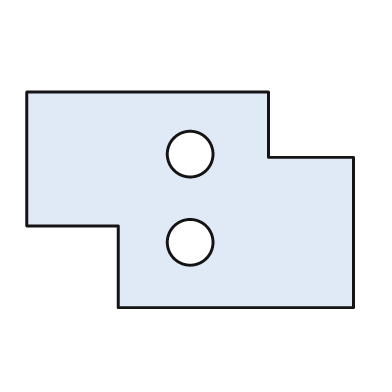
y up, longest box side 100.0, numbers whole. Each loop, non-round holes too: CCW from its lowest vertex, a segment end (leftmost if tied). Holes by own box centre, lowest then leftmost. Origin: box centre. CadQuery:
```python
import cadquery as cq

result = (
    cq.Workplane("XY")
    .moveTo(-22.0, -33.0)
    .lineTo(50.0, -33.0)
    .lineTo(50.0, 13.0)
    .lineTo(24.0, 13.0)
    .lineTo(24.0, 33.0)
    .lineTo(-50.0, 33.0)
    .lineTo(-50.0, -8.0)
    .lineTo(-22.0, -8.0)
    .close()
    .moveTo(0.0, -13.0)
    .circle(7.0)
    .moveTo(0.0, 14.0)
    .circle(7.0)
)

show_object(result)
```